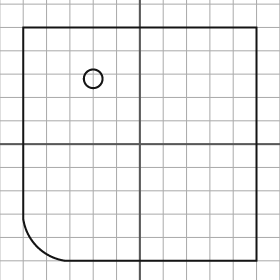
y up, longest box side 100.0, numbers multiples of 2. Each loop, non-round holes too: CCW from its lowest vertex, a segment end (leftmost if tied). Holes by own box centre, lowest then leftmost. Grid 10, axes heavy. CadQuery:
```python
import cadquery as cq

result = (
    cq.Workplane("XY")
    .moveTo(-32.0, -50.0)
    .lineTo(50.0, -50.0)
    .lineTo(50.0, 50.0)
    .lineTo(-50.0, 50.0)
    .lineTo(-50.0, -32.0)
    .threePointArc((-44.0, -44.0), (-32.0, -50.0))
    .close()
    .moveTo(-20.0, 28.0)
    .circle(4.0)
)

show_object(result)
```